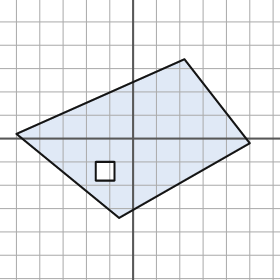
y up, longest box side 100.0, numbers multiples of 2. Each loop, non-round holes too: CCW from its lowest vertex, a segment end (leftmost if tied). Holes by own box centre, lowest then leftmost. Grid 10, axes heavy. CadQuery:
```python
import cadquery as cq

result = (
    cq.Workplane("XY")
    .moveTo(-6.0, -34.0)
    .lineTo(50.0, -2.0)
    .lineTo(22.0, 34.0)
    .lineTo(-50.0, 2.0)
    .close()
    .moveTo(-16.0, -18.0)
    .lineTo(-8.0, -18.0)
    .lineTo(-8.0, -10.0)
    .lineTo(-16.0, -10.0)
    .close()
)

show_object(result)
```